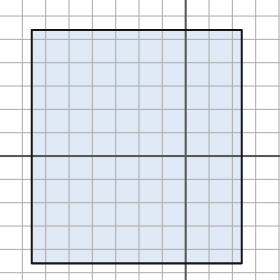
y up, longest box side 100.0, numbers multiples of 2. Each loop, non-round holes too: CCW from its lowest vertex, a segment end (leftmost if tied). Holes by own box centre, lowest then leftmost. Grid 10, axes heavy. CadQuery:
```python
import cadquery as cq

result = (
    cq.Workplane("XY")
    .moveTo(-66.0, -46.0)
    .lineTo(24.0, -46.0)
    .lineTo(24.0, 54.0)
    .lineTo(-66.0, 54.0)
    .close()
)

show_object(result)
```